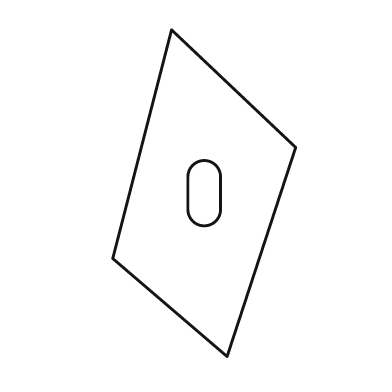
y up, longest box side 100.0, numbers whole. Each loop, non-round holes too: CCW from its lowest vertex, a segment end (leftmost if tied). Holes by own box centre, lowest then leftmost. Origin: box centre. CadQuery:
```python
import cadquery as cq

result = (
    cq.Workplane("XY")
    .moveTo(7.0, -50.0)
    .lineTo(28.0, 14.0)
    .lineTo(-10.0, 50.0)
    .lineTo(-28.0, -20.0)
    .close()
    .moveTo(-5.0, -5.0)
    .threePointArc((0.0, -10.0), (5.0, -5.0))
    .lineTo(5.0, 5.0)
    .threePointArc((0.0, 10.0), (-5.0, 5.0))
    .close()
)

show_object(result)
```